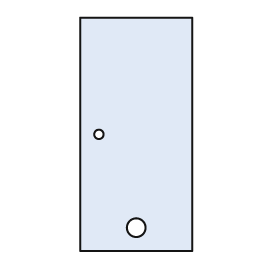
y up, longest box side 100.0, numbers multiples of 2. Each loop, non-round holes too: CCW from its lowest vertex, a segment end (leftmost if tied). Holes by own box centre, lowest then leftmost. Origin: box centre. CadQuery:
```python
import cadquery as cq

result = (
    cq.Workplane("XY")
    .moveTo(-24.0, -50.0)
    .lineTo(24.0, -50.0)
    .lineTo(24.0, 50.0)
    .lineTo(-24.0, 50.0)
    .close()
    .moveTo(0.0, -40.0)
    .circle(4.0)
    .moveTo(-16.0, 0.0)
    .circle(2.0)
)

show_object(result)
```